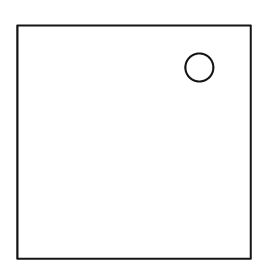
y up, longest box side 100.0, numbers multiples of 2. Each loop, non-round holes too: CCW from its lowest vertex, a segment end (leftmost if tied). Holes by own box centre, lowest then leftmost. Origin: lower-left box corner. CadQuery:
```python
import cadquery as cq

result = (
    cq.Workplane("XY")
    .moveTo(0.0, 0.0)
    .lineTo(100.0, 0.0)
    .lineTo(100.0, 100.0)
    .lineTo(0.0, 100.0)
    .close()
    .moveTo(78.0, 82.0)
    .circle(6.0)
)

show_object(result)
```